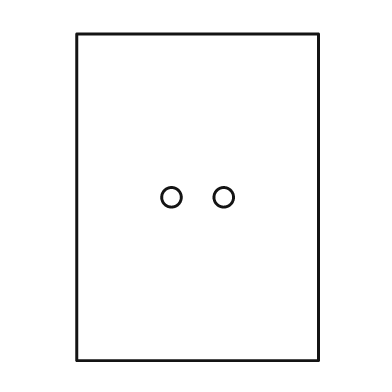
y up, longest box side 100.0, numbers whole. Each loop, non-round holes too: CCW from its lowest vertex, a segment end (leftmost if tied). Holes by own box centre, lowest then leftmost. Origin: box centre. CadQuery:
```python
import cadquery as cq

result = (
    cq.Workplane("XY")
    .moveTo(-37.0, -50.0)
    .lineTo(37.0, -50.0)
    .lineTo(37.0, 50.0)
    .lineTo(-37.0, 50.0)
    .close()
    .moveTo(-8.0, 0.0)
    .circle(3.0)
    .moveTo(8.0, 0.0)
    .circle(3.0)
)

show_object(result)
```